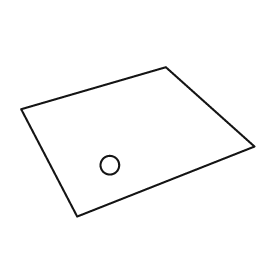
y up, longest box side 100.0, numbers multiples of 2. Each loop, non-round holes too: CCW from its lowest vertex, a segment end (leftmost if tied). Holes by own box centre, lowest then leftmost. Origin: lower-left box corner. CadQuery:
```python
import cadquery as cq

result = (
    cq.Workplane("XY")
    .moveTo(24.0, 0.0)
    .lineTo(100.0, 30.0)
    .lineTo(62.0, 64.0)
    .lineTo(0.0, 46.0)
    .close()
    .moveTo(38.0, 22.0)
    .circle(4.0)
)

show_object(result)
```